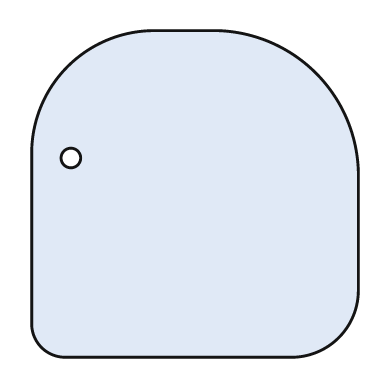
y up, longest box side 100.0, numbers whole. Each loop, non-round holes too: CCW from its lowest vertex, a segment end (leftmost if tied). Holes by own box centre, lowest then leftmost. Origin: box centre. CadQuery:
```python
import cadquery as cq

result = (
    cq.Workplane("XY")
    .moveTo(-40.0, -50.0)
    .lineTo(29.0, -50.0)
    .threePointArc((44.0, -44.0), (50.0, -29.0))
    .lineTo(50.0, 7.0)
    .threePointArc((37.0, 37.0), (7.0, 50.0))
    .lineTo(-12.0, 50.0)
    .threePointArc((-39.0, 39.0), (-50.0, 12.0))
    .lineTo(-50.0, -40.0)
    .threePointArc((-47.0, -47.0), (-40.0, -50.0))
    .close()
    .moveTo(-38.0, 11.0)
    .circle(3.0)
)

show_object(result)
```